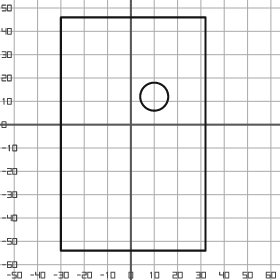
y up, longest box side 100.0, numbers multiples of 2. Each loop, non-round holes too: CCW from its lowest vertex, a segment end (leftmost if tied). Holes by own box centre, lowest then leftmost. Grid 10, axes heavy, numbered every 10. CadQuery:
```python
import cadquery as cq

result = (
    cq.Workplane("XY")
    .moveTo(-30.0, -54.0)
    .lineTo(32.0, -54.0)
    .lineTo(32.0, 46.0)
    .lineTo(-30.0, 46.0)
    .close()
    .moveTo(10.0, 12.0)
    .circle(6.0)
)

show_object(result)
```